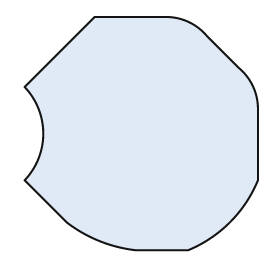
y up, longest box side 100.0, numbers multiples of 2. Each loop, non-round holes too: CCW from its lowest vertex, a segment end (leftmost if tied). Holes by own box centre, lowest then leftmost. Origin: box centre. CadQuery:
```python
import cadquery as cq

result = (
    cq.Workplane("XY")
    .moveTo(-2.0, -50.0)
    .lineTo(20.0, -50.0)
    .threePointArc((38.0, -38.0), (50.0, -20.0))
    .lineTo(50.0, 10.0)
    .threePointArc((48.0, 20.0), (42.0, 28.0))
    .lineTo(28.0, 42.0)
    .threePointArc((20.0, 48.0), (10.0, 50.0))
    .lineTo(-20.0, 50.0)
    .lineTo(-50.0, 20.0)
    .threePointArc((-42.0, 0.0), (-50.0, -20.0))
    .lineTo(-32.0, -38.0)
    .threePointArc((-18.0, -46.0), (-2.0, -50.0))
    .close()
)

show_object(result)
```